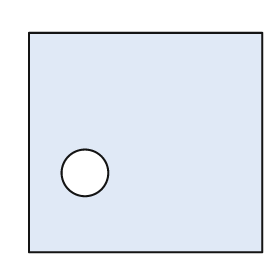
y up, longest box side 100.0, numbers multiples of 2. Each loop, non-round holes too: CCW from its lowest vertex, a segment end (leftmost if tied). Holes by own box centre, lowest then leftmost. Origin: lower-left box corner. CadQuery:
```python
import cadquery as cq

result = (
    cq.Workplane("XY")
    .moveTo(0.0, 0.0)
    .lineTo(100.0, 0.0)
    .lineTo(100.0, 94.0)
    .lineTo(0.0, 94.0)
    .close()
    .moveTo(24.0, 34.0)
    .circle(10.0)
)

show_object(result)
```